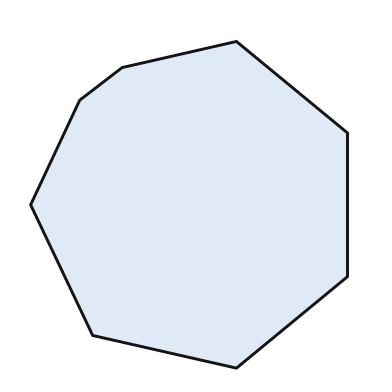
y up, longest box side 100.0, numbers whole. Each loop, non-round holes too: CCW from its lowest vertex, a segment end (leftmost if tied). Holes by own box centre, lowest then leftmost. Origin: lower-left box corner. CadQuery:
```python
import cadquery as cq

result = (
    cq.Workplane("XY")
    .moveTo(63.0, 0.0)
    .lineTo(97.0, 28.0)
    .lineTo(97.0, 72.0)
    .lineTo(63.0, 100.0)
    .lineTo(28.0, 92.0)
    .lineTo(15.0, 82.0)
    .lineTo(0.0, 50.0)
    .lineTo(19.0, 10.0)
    .close()
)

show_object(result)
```